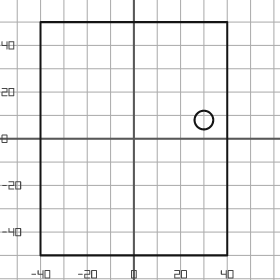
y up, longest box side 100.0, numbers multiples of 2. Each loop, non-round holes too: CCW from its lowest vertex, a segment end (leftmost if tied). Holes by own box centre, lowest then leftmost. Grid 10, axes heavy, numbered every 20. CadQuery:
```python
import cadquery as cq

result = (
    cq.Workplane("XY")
    .moveTo(-40.0, -50.0)
    .lineTo(40.0, -50.0)
    .lineTo(40.0, 50.0)
    .lineTo(-40.0, 50.0)
    .close()
    .moveTo(30.0, 8.0)
    .circle(4.0)
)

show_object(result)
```